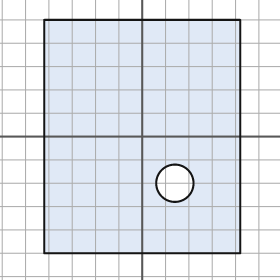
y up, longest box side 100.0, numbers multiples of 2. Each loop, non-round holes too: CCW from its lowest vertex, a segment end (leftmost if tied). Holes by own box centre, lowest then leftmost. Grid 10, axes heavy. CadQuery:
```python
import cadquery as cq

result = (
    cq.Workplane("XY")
    .moveTo(-42.0, -50.0)
    .lineTo(42.0, -50.0)
    .lineTo(42.0, 50.0)
    .lineTo(-42.0, 50.0)
    .close()
    .moveTo(14.0, -20.0)
    .circle(8.0)
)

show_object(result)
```